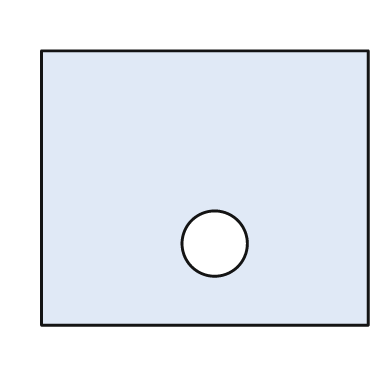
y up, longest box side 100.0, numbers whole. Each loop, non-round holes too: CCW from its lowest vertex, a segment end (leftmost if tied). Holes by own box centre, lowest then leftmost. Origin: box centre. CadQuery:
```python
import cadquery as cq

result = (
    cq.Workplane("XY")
    .moveTo(-50.0, -42.0)
    .lineTo(50.0, -42.0)
    .lineTo(50.0, 42.0)
    .lineTo(-50.0, 42.0)
    .close()
    .moveTo(3.0, -17.0)
    .circle(10.0)
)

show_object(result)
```